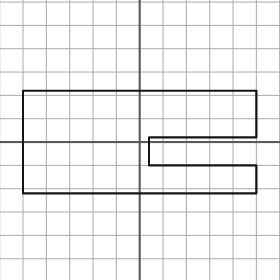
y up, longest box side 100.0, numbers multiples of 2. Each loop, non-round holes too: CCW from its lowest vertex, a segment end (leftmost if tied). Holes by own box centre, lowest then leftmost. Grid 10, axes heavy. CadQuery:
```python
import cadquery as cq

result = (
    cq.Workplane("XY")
    .moveTo(-50.0, -22.0)
    .lineTo(50.0, -22.0)
    .lineTo(50.0, -10.0)
    .lineTo(4.0, -10.0)
    .lineTo(4.0, 2.0)
    .lineTo(50.0, 2.0)
    .lineTo(50.0, 22.0)
    .lineTo(-50.0, 22.0)
    .close()
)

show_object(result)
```